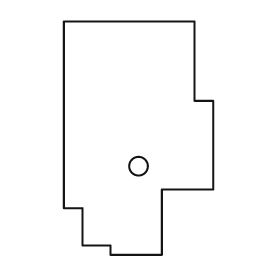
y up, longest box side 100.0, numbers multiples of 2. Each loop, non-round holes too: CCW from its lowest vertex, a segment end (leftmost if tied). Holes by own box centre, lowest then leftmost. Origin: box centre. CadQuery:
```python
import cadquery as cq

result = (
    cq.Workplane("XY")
    .moveTo(-12.0, -50.0)
    .lineTo(10.0, -50.0)
    .lineTo(10.0, -22.0)
    .lineTo(32.0, -22.0)
    .lineTo(32.0, 16.0)
    .lineTo(24.0, 16.0)
    .lineTo(24.0, 50.0)
    .lineTo(-32.0, 50.0)
    .lineTo(-32.0, -30.0)
    .lineTo(-24.0, -30.0)
    .lineTo(-24.0, -46.0)
    .lineTo(-12.0, -46.0)
    .close()
    .moveTo(0.0, -12.0)
    .circle(4.0)
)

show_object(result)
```